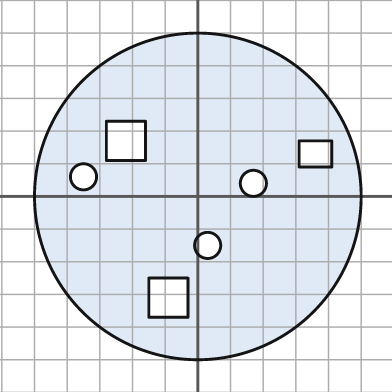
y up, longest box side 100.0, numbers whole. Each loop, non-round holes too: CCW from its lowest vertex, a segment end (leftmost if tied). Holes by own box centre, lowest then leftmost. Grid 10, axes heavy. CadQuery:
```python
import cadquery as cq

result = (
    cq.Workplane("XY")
    .moveTo(0.0, 0.0)
    .circle(50.0)
    .moveTo(-15.0, -37.0)
    .lineTo(-3.0, -37.0)
    .lineTo(-3.0, -25.0)
    .lineTo(-15.0, -25.0)
    .close()
    .moveTo(3.0, -15.0)
    .circle(4.0)
    .moveTo(17.0, 4.0)
    .circle(4.0)
    .moveTo(-35.0, 6.0)
    .circle(4.0)
    .moveTo(31.0, 9.0)
    .lineTo(41.0, 9.0)
    .lineTo(41.0, 17.0)
    .lineTo(31.0, 17.0)
    .close()
    .moveTo(-28.0, 11.0)
    .lineTo(-16.0, 11.0)
    .lineTo(-16.0, 23.0)
    .lineTo(-28.0, 23.0)
    .close()
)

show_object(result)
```